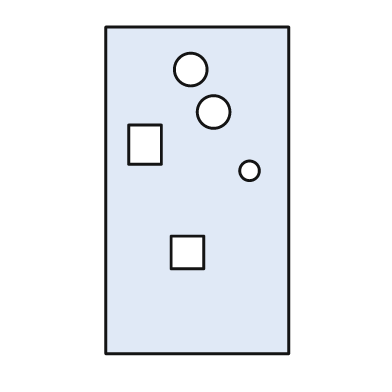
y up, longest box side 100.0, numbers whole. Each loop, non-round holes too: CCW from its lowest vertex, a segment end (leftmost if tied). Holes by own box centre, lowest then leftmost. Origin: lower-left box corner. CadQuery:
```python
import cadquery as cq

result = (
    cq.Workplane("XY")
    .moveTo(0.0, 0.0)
    .lineTo(56.0, 0.0)
    .lineTo(56.0, 100.0)
    .lineTo(0.0, 100.0)
    .close()
    .moveTo(20.0, 26.0)
    .lineTo(30.0, 26.0)
    .lineTo(30.0, 36.0)
    .lineTo(20.0, 36.0)
    .close()
    .moveTo(44.0, 56.0)
    .circle(3.0)
    .moveTo(7.0, 58.0)
    .lineTo(17.0, 58.0)
    .lineTo(17.0, 70.0)
    .lineTo(7.0, 70.0)
    .close()
    .moveTo(33.0, 74.0)
    .circle(5.0)
    .moveTo(26.0, 87.0)
    .circle(5.0)
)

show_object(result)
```